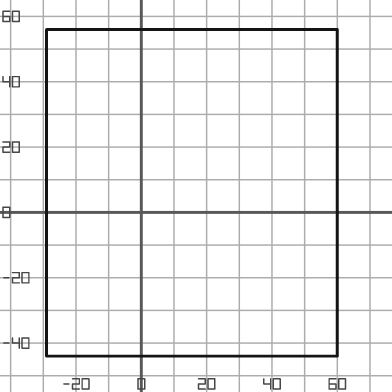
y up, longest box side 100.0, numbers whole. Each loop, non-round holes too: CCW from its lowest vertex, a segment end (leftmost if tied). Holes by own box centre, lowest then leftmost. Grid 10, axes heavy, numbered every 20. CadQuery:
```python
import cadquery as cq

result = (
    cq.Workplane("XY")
    .moveTo(-29.0, -44.0)
    .lineTo(60.0, -44.0)
    .lineTo(60.0, 56.0)
    .lineTo(-29.0, 56.0)
    .close()
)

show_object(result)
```